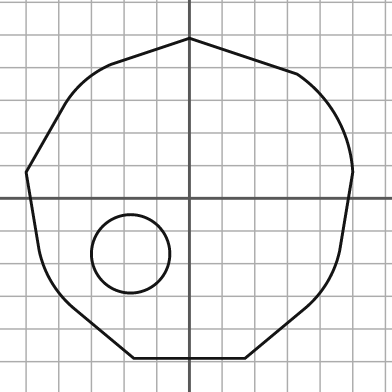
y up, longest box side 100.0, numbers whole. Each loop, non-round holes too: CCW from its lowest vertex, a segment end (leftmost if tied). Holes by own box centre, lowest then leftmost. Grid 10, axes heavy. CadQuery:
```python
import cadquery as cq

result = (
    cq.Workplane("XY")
    .moveTo(-17.0, -49.0)
    .lineTo(17.0, -49.0)
    .lineTo(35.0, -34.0)
    .threePointArc((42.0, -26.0), (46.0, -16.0))
    .lineTo(50.0, 8.0)
    .threePointArc((45.0, 25.0), (33.0, 38.0))
    .lineTo(0.0, 49.0)
    .lineTo(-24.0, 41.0)
    .threePointArc((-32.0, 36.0), (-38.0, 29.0))
    .lineTo(-50.0, 8.0)
    .lineTo(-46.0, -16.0)
    .threePointArc((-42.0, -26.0), (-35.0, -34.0))
    .close()
    .moveTo(-18.0, -17.0)
    .circle(12.0)
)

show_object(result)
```